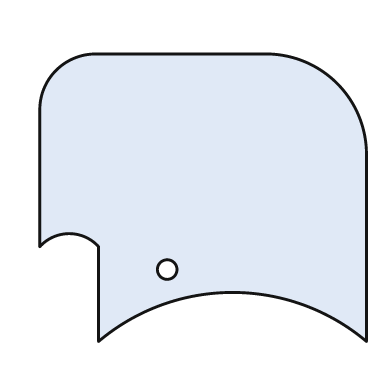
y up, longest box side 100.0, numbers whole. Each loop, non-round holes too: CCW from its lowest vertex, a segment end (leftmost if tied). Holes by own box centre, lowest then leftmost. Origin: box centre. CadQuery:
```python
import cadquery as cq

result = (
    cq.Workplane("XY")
    .moveTo(-32.0, -44.0)
    .threePointArc((9.0, -29.0), (50.0, -44.0))
    .lineTo(50.0, 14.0)
    .threePointArc((41.0, 35.0), (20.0, 44.0))
    .lineTo(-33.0, 44.0)
    .threePointArc((-45.0, 39.0), (-50.0, 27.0))
    .lineTo(-50.0, -15.0)
    .threePointArc((-41.0, -11.0), (-32.0, -15.0))
    .close()
    .moveTo(-11.0, -22.0)
    .circle(3.0)
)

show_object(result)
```